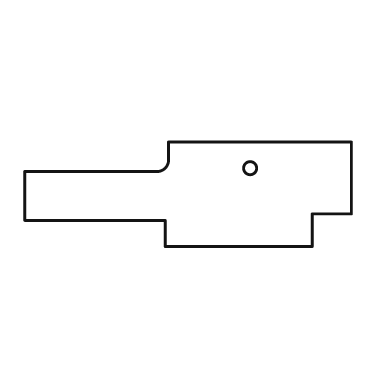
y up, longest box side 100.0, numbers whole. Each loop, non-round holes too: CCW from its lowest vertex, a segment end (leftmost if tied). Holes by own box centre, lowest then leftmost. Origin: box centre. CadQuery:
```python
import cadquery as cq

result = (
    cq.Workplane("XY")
    .moveTo(-7.0, -16.0)
    .lineTo(38.0, -16.0)
    .lineTo(38.0, -6.0)
    .lineTo(50.0, -6.0)
    .lineTo(50.0, 16.0)
    .lineTo(-6.0, 16.0)
    .lineTo(-6.0, 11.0)
    .threePointArc((-7.0, 8.0), (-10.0, 7.0))
    .lineTo(-50.0, 7.0)
    .lineTo(-50.0, -8.0)
    .lineTo(-7.0, -8.0)
    .close()
    .moveTo(19.0, 8.0)
    .circle(2.0)
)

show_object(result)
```